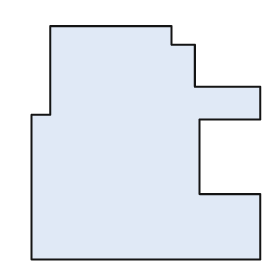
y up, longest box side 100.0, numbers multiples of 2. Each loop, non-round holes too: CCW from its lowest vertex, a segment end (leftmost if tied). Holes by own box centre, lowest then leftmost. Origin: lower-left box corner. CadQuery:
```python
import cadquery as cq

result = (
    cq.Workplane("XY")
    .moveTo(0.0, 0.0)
    .lineTo(98.0, 0.0)
    .lineTo(98.0, 28.0)
    .lineTo(72.0, 28.0)
    .lineTo(72.0, 60.0)
    .lineTo(98.0, 60.0)
    .lineTo(98.0, 74.0)
    .lineTo(70.0, 74.0)
    .lineTo(70.0, 92.0)
    .lineTo(60.0, 92.0)
    .lineTo(60.0, 100.0)
    .lineTo(8.0, 100.0)
    .lineTo(8.0, 62.0)
    .lineTo(0.0, 62.0)
    .close()
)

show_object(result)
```